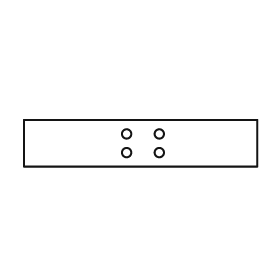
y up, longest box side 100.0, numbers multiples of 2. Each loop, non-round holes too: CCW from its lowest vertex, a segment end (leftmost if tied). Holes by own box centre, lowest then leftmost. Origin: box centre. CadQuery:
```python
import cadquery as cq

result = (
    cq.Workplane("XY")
    .moveTo(-50.0, -10.0)
    .lineTo(50.0, -10.0)
    .lineTo(50.0, 10.0)
    .lineTo(-50.0, 10.0)
    .close()
    .moveTo(-6.0, -4.0)
    .circle(2.0)
    .moveTo(8.0, -4.0)
    .circle(2.0)
    .moveTo(-6.0, 4.0)
    .circle(2.0)
    .moveTo(8.0, 4.0)
    .circle(2.0)
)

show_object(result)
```